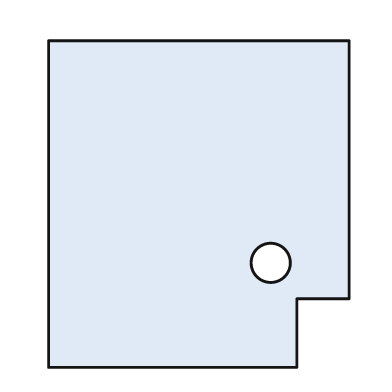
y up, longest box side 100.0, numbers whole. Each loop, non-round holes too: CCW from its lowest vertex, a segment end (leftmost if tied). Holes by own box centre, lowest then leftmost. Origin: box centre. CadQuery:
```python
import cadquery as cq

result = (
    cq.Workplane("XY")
    .moveTo(-46.0, -50.0)
    .lineTo(30.0, -50.0)
    .lineTo(30.0, -29.0)
    .lineTo(46.0, -29.0)
    .lineTo(46.0, 50.0)
    .lineTo(-46.0, 50.0)
    .close()
    .moveTo(22.0, -18.0)
    .circle(6.0)
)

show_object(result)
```